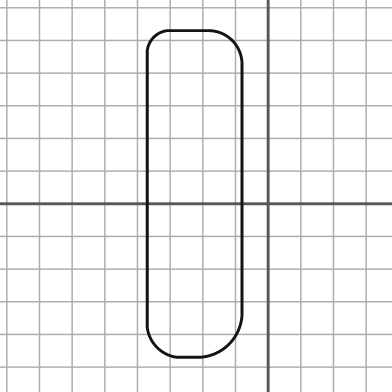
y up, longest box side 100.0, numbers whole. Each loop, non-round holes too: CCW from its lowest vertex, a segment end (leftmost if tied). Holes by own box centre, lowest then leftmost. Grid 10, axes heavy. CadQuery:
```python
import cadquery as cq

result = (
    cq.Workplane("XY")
    .moveTo(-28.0, -47.0)
    .lineTo(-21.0, -47.0)
    .threePointArc((-12.0, -43.0), (-8.0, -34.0))
    .lineTo(-8.0, 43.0)
    .threePointArc((-11.0, 50.0), (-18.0, 53.0))
    .lineTo(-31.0, 53.0)
    .threePointArc((-35.0, 51.0), (-37.0, 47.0))
    .lineTo(-37.0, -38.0)
    .threePointArc((-34.0, -44.0), (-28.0, -47.0))
    .close()
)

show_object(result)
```